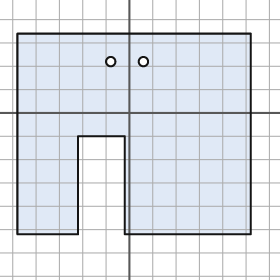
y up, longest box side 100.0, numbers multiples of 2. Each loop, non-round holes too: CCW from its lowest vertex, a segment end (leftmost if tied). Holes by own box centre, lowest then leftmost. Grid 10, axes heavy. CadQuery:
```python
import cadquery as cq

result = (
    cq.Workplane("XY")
    .moveTo(-48.0, -52.0)
    .lineTo(-22.0, -52.0)
    .lineTo(-22.0, -10.0)
    .lineTo(-2.0, -10.0)
    .lineTo(-2.0, -52.0)
    .lineTo(52.0, -52.0)
    .lineTo(52.0, 34.0)
    .lineTo(-48.0, 34.0)
    .close()
    .moveTo(-8.0, 22.0)
    .circle(2.0)
    .moveTo(6.0, 22.0)
    .circle(2.0)
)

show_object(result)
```